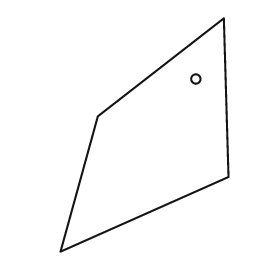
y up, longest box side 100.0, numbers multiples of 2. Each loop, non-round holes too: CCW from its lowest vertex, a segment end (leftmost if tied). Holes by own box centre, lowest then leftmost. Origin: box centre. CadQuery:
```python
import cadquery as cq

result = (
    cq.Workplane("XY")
    .moveTo(-36.0, -50.0)
    .lineTo(36.0, -18.0)
    .lineTo(34.0, 50.0)
    .lineTo(-20.0, 8.0)
    .close()
    .moveTo(22.0, 24.0)
    .circle(2.0)
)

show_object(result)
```